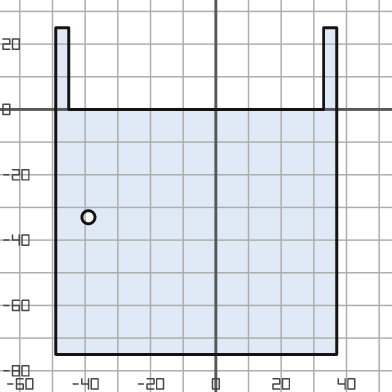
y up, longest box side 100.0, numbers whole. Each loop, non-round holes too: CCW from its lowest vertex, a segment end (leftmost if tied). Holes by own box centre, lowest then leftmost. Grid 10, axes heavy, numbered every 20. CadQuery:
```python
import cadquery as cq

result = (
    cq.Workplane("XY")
    .moveTo(-49.0, -75.0)
    .lineTo(37.0, -75.0)
    .lineTo(37.0, 25.0)
    .lineTo(33.0, 25.0)
    .lineTo(33.0, 0.0)
    .lineTo(-45.0, 0.0)
    .lineTo(-45.0, 25.0)
    .lineTo(-49.0, 25.0)
    .close()
    .moveTo(-39.0, -33.0)
    .circle(2.0)
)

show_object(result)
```